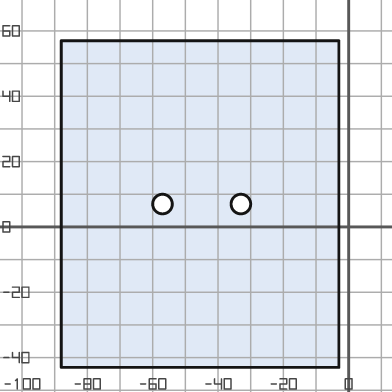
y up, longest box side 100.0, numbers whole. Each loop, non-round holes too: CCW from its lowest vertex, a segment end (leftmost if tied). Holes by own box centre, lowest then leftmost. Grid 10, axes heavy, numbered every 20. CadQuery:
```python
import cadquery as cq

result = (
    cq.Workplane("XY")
    .moveTo(-88.0, -43.0)
    .lineTo(-3.0, -43.0)
    .lineTo(-3.0, 57.0)
    .lineTo(-88.0, 57.0)
    .close()
    .moveTo(-57.0, 7.0)
    .circle(3.0)
    .moveTo(-33.0, 7.0)
    .circle(3.0)
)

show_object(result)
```